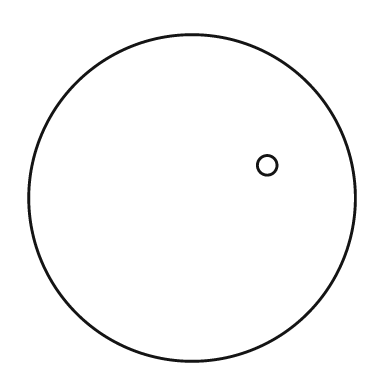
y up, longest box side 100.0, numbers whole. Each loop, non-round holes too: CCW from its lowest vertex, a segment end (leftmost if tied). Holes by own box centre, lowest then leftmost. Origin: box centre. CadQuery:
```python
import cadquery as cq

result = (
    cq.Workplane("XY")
    .moveTo(0.0, 0.0)
    .circle(50.0)
    .moveTo(23.0, 10.0)
    .circle(3.0)
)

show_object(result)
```